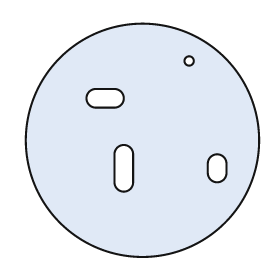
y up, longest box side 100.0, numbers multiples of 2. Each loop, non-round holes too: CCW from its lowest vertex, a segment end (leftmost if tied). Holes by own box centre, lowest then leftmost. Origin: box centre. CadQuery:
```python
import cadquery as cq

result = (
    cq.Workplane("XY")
    .moveTo(0.0, 0.0)
    .circle(50.0)
    .moveTo(-12.0, -18.0)
    .threePointArc((-8.0, -22.0), (-4.0, -18.0))
    .lineTo(-4.0, -6.0)
    .threePointArc((-8.0, -2.0), (-12.0, -6.0))
    .close()
    .moveTo(28.0, -14.0)
    .threePointArc((32.0, -18.0), (36.0, -14.0))
    .lineTo(36.0, -10.0)
    .threePointArc((32.0, -6.0), (28.0, -10.0))
    .close()
    .moveTo(-20.0, 14.0)
    .lineTo(-12.0, 14.0)
    .threePointArc((-8.0, 18.0), (-12.0, 22.0))
    .lineTo(-20.0, 22.0)
    .threePointArc((-24.0, 18.0), (-20.0, 14.0))
    .close()
    .moveTo(20.0, 34.0)
    .circle(2.0)
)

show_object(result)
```